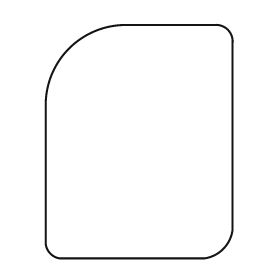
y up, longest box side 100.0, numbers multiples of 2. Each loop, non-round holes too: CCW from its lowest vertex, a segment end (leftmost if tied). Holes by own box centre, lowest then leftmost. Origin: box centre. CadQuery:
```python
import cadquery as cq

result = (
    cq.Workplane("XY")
    .moveTo(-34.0, -50.0)
    .lineTo(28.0, -50.0)
    .threePointArc((36.0, -46.0), (40.0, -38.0))
    .lineTo(40.0, 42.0)
    .threePointArc((38.0, 48.0), (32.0, 50.0))
    .lineTo(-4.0, 50.0)
    .threePointArc((-30.0, 40.0), (-40.0, 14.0))
    .lineTo(-40.0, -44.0)
    .threePointArc((-38.0, -48.0), (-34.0, -50.0))
    .close()
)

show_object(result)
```